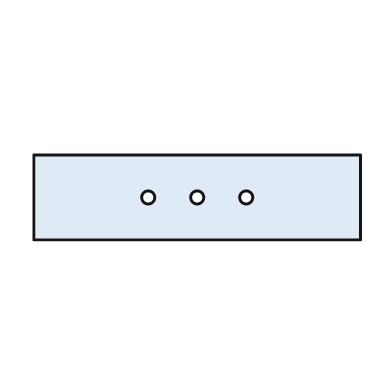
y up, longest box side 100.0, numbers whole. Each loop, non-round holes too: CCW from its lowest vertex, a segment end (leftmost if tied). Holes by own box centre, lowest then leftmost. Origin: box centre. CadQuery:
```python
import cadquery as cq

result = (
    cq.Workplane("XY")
    .moveTo(-50.0, -13.0)
    .lineTo(50.0, -13.0)
    .lineTo(50.0, 13.0)
    .lineTo(-50.0, 13.0)
    .close()
    .moveTo(-15.0, 0.0)
    .circle(2.0)
    .moveTo(0.0, 0.0)
    .circle(2.0)
    .moveTo(15.0, 0.0)
    .circle(2.0)
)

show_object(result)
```